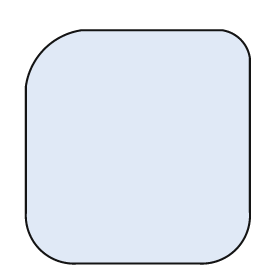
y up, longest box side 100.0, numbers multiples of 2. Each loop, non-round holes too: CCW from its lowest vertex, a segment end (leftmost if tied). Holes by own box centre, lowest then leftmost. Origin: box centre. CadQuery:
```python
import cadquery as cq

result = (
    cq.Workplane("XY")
    .moveTo(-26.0, -50.0)
    .lineTo(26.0, -50.0)
    .threePointArc((42.0, -44.0), (48.0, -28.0))
    .lineTo(48.0, 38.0)
    .threePointArc((44.0, 46.0), (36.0, 50.0))
    .lineTo(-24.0, 50.0)
    .threePointArc((-40.0, 42.0), (-48.0, 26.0))
    .lineTo(-48.0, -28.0)
    .threePointArc((-42.0, -44.0), (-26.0, -50.0))
    .close()
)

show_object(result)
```